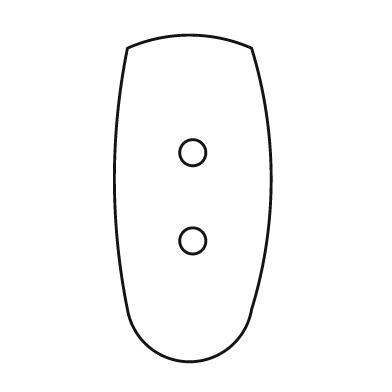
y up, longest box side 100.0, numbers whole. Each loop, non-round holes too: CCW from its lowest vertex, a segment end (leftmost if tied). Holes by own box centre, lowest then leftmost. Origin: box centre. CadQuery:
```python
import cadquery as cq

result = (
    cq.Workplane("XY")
    .moveTo(-20.0, -34.0)
    .threePointArc((-1.0, -50.0), (18.0, -34.0))
    .threePointArc((24.0, 6.0), (18.0, 46.0))
    .threePointArc((-1.0, 50.0), (-20.0, 46.0))
    .threePointArc((-24.0, 6.0), (-20.0, -34.0))
    .close()
    .moveTo(0.0, -13.0)
    .circle(4.0)
    .moveTo(0.0, 14.0)
    .circle(4.0)
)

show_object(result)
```